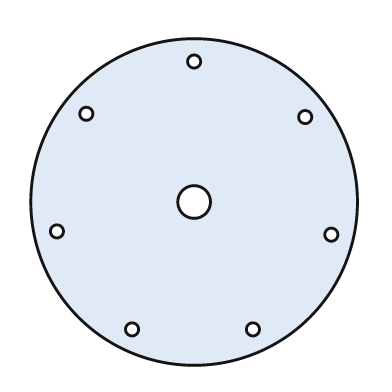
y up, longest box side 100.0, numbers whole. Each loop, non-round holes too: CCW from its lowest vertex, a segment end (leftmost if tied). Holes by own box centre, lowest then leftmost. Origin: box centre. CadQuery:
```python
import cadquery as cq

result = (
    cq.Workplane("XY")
    .moveTo(0.0, 0.0)
    .circle(50.0)
    .moveTo(-19.0, -39.0)
    .circle(2.0)
    .moveTo(18.0, -39.0)
    .circle(2.0)
    .moveTo(42.0, -10.0)
    .circle(2.0)
    .moveTo(-42.0, -9.0)
    .circle(2.0)
    .moveTo(0.0, 0.0)
    .circle(5.0)
    .moveTo(34.0, 26.0)
    .circle(2.0)
    .moveTo(-33.0, 27.0)
    .circle(2.0)
    .moveTo(0.0, 43.0)
    .circle(2.0)
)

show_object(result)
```